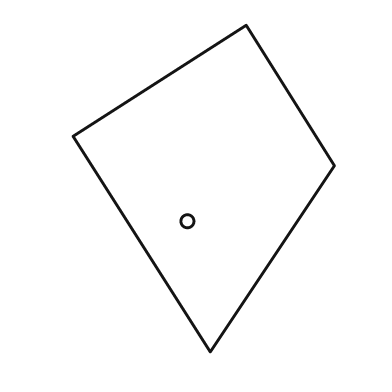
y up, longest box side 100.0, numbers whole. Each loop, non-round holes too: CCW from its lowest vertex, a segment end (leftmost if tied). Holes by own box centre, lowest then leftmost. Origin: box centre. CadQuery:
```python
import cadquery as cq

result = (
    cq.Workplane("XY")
    .moveTo(2.0, -50.0)
    .lineTo(40.0, 7.0)
    .lineTo(13.0, 50.0)
    .lineTo(-40.0, 16.0)
    .close()
    .moveTo(-5.0, -10.0)
    .circle(2.0)
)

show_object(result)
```